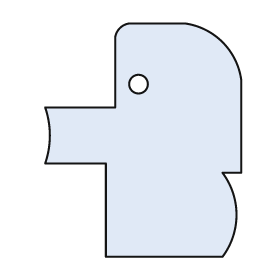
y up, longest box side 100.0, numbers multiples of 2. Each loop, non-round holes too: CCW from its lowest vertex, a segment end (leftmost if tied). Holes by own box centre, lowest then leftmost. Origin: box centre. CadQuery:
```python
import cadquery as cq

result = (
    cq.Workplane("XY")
    .moveTo(-16.0, -50.0)
    .lineTo(34.0, -50.0)
    .threePointArc((40.0, -32.0), (34.0, -14.0))
    .lineTo(42.0, -14.0)
    .lineTo(42.0, 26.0)
    .threePointArc((34.0, 42.0), (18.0, 50.0))
    .lineTo(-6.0, 50.0)
    .threePointArc((-10.0, 48.0), (-12.0, 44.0))
    .lineTo(-12.0, 14.0)
    .lineTo(-42.0, 14.0)
    .threePointArc((-40.0, 2.0), (-42.0, -10.0))
    .lineTo(-16.0, -10.0)
    .close()
    .moveTo(-2.0, 24.0)
    .circle(4.0)
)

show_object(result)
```